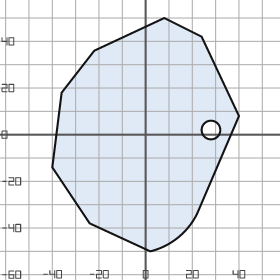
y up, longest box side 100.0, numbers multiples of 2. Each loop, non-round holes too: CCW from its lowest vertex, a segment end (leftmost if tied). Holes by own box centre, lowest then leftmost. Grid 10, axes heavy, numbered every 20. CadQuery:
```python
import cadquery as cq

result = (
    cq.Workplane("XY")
    .moveTo(2.0, -50.0)
    .threePointArc((14.0, -44.0), (22.0, -34.0))
    .lineTo(40.0, 8.0)
    .lineTo(24.0, 42.0)
    .lineTo(8.0, 50.0)
    .lineTo(-22.0, 36.0)
    .lineTo(-36.0, 18.0)
    .lineTo(-40.0, -14.0)
    .lineTo(-24.0, -38.0)
    .close()
    .moveTo(28.0, 2.0)
    .circle(4.0)
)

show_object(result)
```